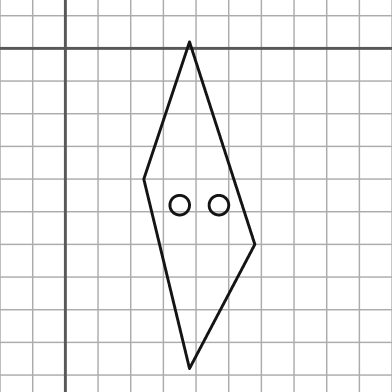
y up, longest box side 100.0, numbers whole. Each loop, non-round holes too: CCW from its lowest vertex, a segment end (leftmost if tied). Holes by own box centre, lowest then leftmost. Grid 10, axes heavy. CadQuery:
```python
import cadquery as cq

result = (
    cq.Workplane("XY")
    .moveTo(38.0, -98.0)
    .lineTo(58.0, -60.0)
    .lineTo(38.0, 2.0)
    .lineTo(24.0, -40.0)
    .close()
    .moveTo(35.0, -48.0)
    .circle(3.0)
    .moveTo(47.0, -48.0)
    .circle(3.0)
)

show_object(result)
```